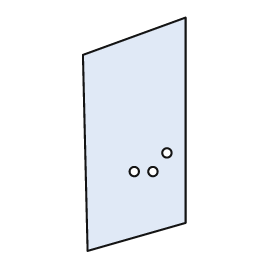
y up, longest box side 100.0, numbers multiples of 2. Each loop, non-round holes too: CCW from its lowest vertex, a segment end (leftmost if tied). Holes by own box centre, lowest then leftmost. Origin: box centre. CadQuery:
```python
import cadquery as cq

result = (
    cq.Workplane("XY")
    .moveTo(-20.0, -50.0)
    .lineTo(22.0, -38.0)
    .lineTo(22.0, 50.0)
    .lineTo(-22.0, 34.0)
    .close()
    .moveTo(0.0, -16.0)
    .circle(2.0)
    .moveTo(8.0, -16.0)
    .circle(2.0)
    .moveTo(14.0, -8.0)
    .circle(2.0)
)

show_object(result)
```